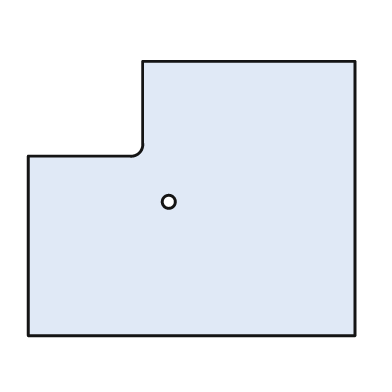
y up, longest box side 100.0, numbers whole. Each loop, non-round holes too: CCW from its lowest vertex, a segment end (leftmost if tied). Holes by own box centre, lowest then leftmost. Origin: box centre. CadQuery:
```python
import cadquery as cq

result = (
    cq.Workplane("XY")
    .moveTo(-50.0, -42.0)
    .lineTo(50.0, -42.0)
    .lineTo(50.0, 42.0)
    .lineTo(-15.0, 42.0)
    .lineTo(-15.0, 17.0)
    .threePointArc((-16.0, 14.0), (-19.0, 13.0))
    .lineTo(-50.0, 13.0)
    .close()
    .moveTo(-7.0, -1.0)
    .circle(2.0)
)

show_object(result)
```